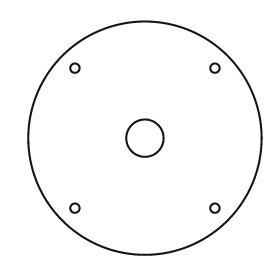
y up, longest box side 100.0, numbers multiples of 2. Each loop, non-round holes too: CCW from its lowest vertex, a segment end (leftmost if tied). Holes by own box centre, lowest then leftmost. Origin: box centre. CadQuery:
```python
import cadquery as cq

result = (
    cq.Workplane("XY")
    .moveTo(0.0, 0.0)
    .circle(50.0)
    .moveTo(-30.0, -30.0)
    .circle(2.0)
    .moveTo(30.0, -30.0)
    .circle(2.0)
    .moveTo(0.0, 0.0)
    .circle(8.0)
    .moveTo(-30.0, 30.0)
    .circle(2.0)
    .moveTo(30.0, 30.0)
    .circle(2.0)
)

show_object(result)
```